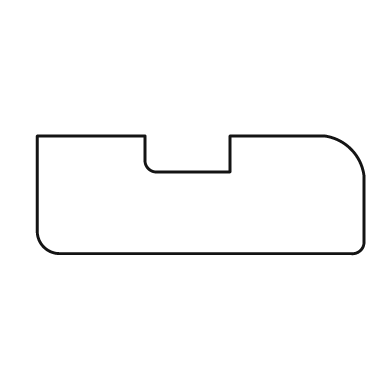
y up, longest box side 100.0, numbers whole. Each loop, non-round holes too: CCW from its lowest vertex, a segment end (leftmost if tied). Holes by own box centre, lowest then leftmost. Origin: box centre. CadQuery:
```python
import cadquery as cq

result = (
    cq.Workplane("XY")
    .moveTo(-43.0, -18.0)
    .lineTo(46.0, -18.0)
    .threePointArc((49.0, -17.0), (50.0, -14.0))
    .lineTo(50.0, 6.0)
    .threePointArc((46.0, 14.0), (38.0, 18.0))
    .lineTo(9.0, 18.0)
    .lineTo(9.0, 7.0)
    .lineTo(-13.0, 7.0)
    .threePointArc((-16.0, 8.0), (-17.0, 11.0))
    .lineTo(-17.0, 18.0)
    .lineTo(-50.0, 18.0)
    .lineTo(-50.0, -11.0)
    .threePointArc((-48.0, -16.0), (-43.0, -18.0))
    .close()
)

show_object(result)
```